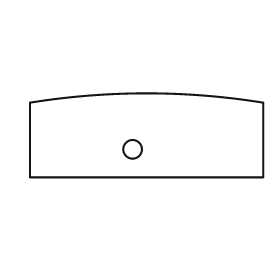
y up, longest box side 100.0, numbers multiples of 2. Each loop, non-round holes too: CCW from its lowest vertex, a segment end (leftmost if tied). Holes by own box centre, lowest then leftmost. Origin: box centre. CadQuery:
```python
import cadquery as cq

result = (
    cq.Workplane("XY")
    .moveTo(-50.0, -18.0)
    .lineTo(50.0, -18.0)
    .lineTo(50.0, 14.0)
    .threePointArc((0.0, 18.0), (-50.0, 14.0))
    .close()
    .moveTo(-6.0, -6.0)
    .circle(4.0)
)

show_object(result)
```